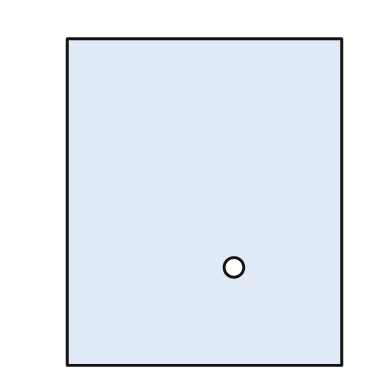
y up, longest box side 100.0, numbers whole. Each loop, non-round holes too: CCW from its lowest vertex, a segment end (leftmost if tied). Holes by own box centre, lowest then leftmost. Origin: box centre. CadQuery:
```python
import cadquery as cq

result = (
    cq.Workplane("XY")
    .moveTo(-42.0, -50.0)
    .lineTo(42.0, -50.0)
    .lineTo(42.0, 50.0)
    .lineTo(-42.0, 50.0)
    .close()
    .moveTo(9.0, -20.0)
    .circle(3.0)
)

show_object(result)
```